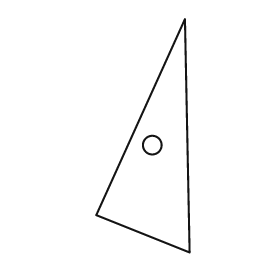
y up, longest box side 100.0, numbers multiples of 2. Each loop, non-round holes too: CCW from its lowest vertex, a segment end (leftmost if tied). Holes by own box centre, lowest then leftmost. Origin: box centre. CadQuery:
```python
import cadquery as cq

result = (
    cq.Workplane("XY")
    .moveTo(20.0, -50.0)
    .lineTo(18.0, 50.0)
    .lineTo(-20.0, -34.0)
    .close()
    .moveTo(4.0, -4.0)
    .circle(4.0)
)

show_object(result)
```